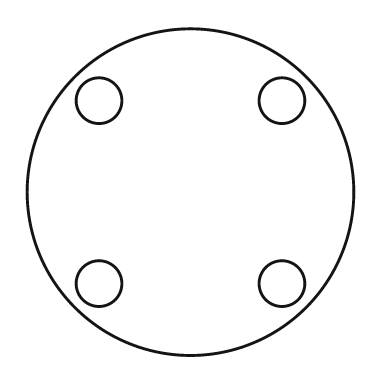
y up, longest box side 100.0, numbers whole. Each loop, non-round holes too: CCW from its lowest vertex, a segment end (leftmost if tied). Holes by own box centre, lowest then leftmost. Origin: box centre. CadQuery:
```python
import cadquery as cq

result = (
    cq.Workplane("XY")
    .moveTo(0.0, 0.0)
    .circle(50.0)
    .moveTo(-28.0, -28.0)
    .circle(7.0)
    .moveTo(28.0, -28.0)
    .circle(7.0)
    .moveTo(-28.0, 28.0)
    .circle(7.0)
    .moveTo(28.0, 28.0)
    .circle(7.0)
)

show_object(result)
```